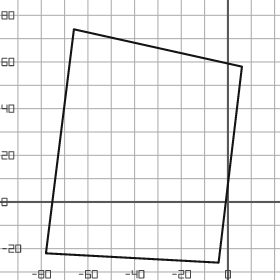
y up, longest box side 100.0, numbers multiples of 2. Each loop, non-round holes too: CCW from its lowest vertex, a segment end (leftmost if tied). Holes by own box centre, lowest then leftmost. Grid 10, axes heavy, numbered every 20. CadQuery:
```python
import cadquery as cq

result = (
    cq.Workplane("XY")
    .moveTo(-4.0, -26.0)
    .lineTo(6.0, 58.0)
    .lineTo(-66.0, 74.0)
    .lineTo(-78.0, -22.0)
    .close()
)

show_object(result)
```